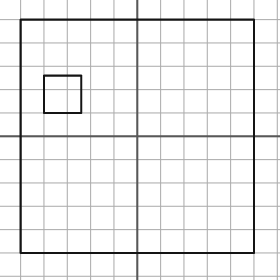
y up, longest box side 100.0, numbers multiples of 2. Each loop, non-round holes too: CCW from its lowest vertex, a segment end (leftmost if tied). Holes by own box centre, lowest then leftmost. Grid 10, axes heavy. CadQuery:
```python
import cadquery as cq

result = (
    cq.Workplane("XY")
    .moveTo(-50.0, -50.0)
    .lineTo(50.0, -50.0)
    .lineTo(50.0, 50.0)
    .lineTo(-50.0, 50.0)
    .close()
    .moveTo(-40.0, 10.0)
    .lineTo(-24.0, 10.0)
    .lineTo(-24.0, 26.0)
    .lineTo(-40.0, 26.0)
    .close()
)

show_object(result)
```